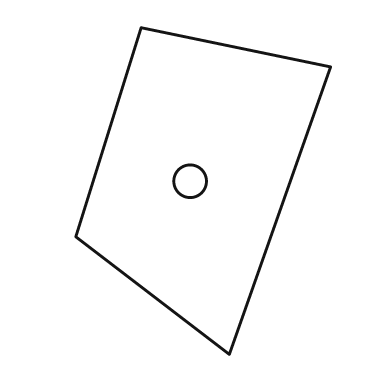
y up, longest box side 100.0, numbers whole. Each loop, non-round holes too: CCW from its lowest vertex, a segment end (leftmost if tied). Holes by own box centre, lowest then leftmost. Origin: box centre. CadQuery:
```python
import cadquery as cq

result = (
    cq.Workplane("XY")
    .moveTo(8.0, -50.0)
    .lineTo(39.0, 38.0)
    .lineTo(-19.0, 50.0)
    .lineTo(-39.0, -14.0)
    .close()
    .moveTo(-4.0, 3.0)
    .circle(5.0)
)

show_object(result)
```